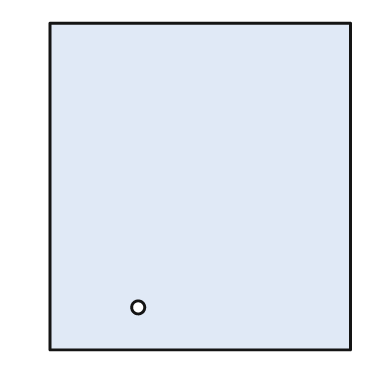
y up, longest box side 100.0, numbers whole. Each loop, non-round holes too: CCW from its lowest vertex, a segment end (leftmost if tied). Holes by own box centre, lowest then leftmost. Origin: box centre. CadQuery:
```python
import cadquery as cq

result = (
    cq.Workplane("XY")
    .moveTo(-46.0, -50.0)
    .lineTo(46.0, -50.0)
    .lineTo(46.0, 50.0)
    .lineTo(-46.0, 50.0)
    .close()
    .moveTo(-19.0, -37.0)
    .circle(2.0)
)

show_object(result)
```